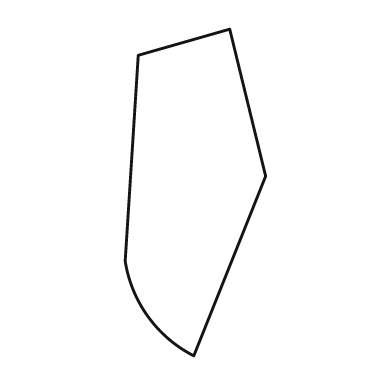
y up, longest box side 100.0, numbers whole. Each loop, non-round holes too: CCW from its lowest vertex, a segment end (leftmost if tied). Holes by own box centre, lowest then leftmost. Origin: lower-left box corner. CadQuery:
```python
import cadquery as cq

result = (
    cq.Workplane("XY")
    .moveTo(21.0, 0.0)
    .lineTo(43.0, 55.0)
    .lineTo(32.0, 100.0)
    .lineTo(4.0, 92.0)
    .lineTo(0.0, 29.0)
    .threePointArc((7.0, 12.0), (21.0, 0.0))
    .close()
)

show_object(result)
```